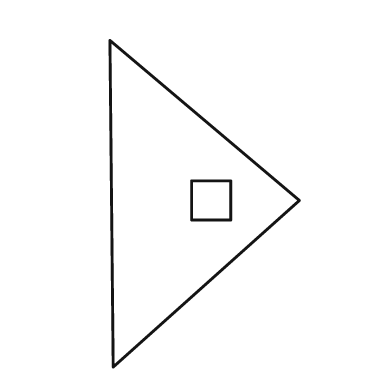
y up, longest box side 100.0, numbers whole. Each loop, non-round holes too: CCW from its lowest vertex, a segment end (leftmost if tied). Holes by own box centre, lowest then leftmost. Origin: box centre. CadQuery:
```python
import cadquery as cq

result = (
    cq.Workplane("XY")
    .moveTo(-28.0, -50.0)
    .lineTo(29.0, 1.0)
    .lineTo(-29.0, 50.0)
    .close()
    .moveTo(-4.0, -5.0)
    .lineTo(8.0, -5.0)
    .lineTo(8.0, 7.0)
    .lineTo(-4.0, 7.0)
    .close()
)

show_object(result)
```